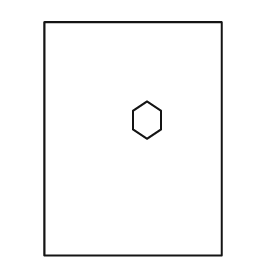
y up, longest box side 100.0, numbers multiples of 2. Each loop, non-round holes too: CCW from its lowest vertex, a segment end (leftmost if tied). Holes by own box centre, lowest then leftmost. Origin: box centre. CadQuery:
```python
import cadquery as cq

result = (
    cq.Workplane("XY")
    .moveTo(-38.0, -50.0)
    .lineTo(38.0, -50.0)
    .lineTo(38.0, 50.0)
    .lineTo(-38.0, 50.0)
    .close()
    .moveTo(6.0, 0.0)
    .lineTo(12.0, 4.0)
    .lineTo(12.0, 12.0)
    .lineTo(6.0, 16.0)
    .lineTo(0.0, 12.0)
    .lineTo(0.0, 4.0)
    .close()
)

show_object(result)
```